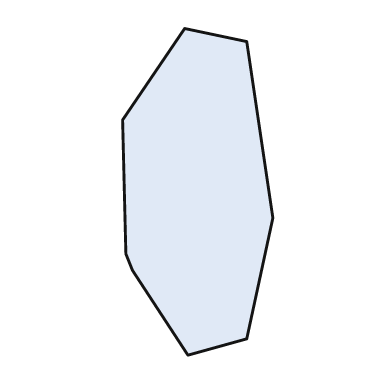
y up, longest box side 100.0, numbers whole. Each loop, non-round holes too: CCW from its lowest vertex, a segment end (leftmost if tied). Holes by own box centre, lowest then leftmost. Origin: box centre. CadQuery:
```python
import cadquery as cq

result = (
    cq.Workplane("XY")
    .moveTo(-3.0, -50.0)
    .lineTo(15.0, -45.0)
    .lineTo(23.0, -8.0)
    .lineTo(15.0, 46.0)
    .lineTo(-4.0, 50.0)
    .lineTo(-23.0, 22.0)
    .lineTo(-22.0, -19.0)
    .lineTo(-20.0, -24.0)
    .close()
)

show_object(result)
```